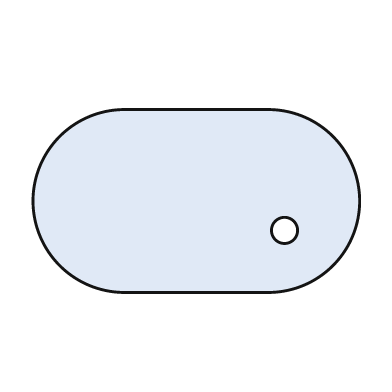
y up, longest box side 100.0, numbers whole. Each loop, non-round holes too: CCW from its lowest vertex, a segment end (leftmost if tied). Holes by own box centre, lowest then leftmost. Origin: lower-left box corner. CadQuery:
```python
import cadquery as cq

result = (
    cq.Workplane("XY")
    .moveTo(28.0, 0.0)
    .lineTo(72.0, 0.0)
    .threePointArc((100.0, 28.0), (72.0, 56.0))
    .lineTo(28.0, 56.0)
    .threePointArc((0.0, 28.0), (28.0, 0.0))
    .close()
    .moveTo(77.0, 19.0)
    .circle(4.0)
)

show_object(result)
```